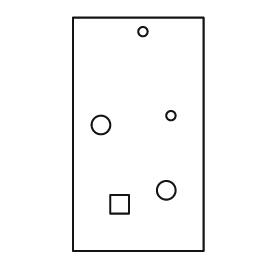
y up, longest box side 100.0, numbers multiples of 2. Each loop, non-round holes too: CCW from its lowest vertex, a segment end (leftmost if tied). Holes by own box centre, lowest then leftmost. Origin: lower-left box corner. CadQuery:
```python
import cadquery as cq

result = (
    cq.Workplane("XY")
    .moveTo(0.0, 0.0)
    .lineTo(56.0, 0.0)
    .lineTo(56.0, 100.0)
    .lineTo(0.0, 100.0)
    .close()
    .moveTo(16.0, 16.0)
    .lineTo(24.0, 16.0)
    .lineTo(24.0, 24.0)
    .lineTo(16.0, 24.0)
    .close()
    .moveTo(40.0, 26.0)
    .circle(4.0)
    .moveTo(12.0, 54.0)
    .circle(4.0)
    .moveTo(42.0, 58.0)
    .circle(2.0)
    .moveTo(30.0, 94.0)
    .circle(2.0)
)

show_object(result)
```